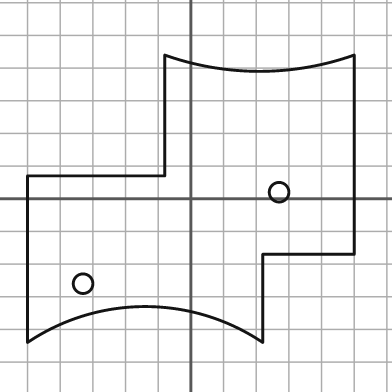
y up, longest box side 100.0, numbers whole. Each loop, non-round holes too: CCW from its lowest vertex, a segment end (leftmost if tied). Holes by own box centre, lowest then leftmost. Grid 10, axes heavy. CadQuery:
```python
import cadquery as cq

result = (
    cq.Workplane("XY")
    .moveTo(-50.0, -44.0)
    .threePointArc((-14.0, -33.0), (22.0, -44.0))
    .lineTo(22.0, -17.0)
    .lineTo(50.0, -17.0)
    .lineTo(50.0, 44.0)
    .threePointArc((21.0, 39.0), (-8.0, 44.0))
    .lineTo(-8.0, 7.0)
    .lineTo(-50.0, 7.0)
    .close()
    .moveTo(-33.0, -26.0)
    .circle(3.0)
    .moveTo(27.0, 2.0)
    .circle(3.0)
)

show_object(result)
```